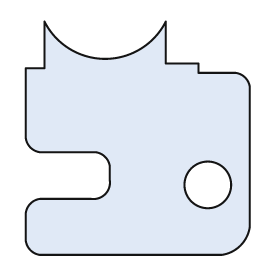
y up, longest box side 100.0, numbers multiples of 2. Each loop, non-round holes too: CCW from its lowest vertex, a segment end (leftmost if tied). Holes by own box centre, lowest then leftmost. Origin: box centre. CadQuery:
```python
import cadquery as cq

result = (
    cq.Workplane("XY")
    .moveTo(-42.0, -50.0)
    .lineTo(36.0, -50.0)
    .threePointArc((44.0, -46.0), (48.0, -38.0))
    .lineTo(48.0, 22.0)
    .threePointArc((46.0, 26.0), (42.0, 28.0))
    .lineTo(26.0, 28.0)
    .lineTo(26.0, 32.0)
    .lineTo(12.0, 32.0)
    .lineTo(12.0, 50.0)
    .threePointArc((-14.0, 34.0), (-40.0, 50.0))
    .lineTo(-40.0, 30.0)
    .lineTo(-48.0, 30.0)
    .lineTo(-48.0, 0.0)
    .threePointArc((-46.0, -4.0), (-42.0, -6.0))
    .lineTo(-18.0, -6.0)
    .threePointArc((-14.0, -8.0), (-12.0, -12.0))
    .lineTo(-12.0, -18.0)
    .threePointArc((-14.0, -24.0), (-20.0, -26.0))
    .lineTo(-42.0, -26.0)
    .threePointArc((-46.0, -28.0), (-48.0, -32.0))
    .lineTo(-48.0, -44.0)
    .threePointArc((-46.0, -48.0), (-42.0, -50.0))
    .close()
    .moveTo(30.0, -20.0)
    .circle(10.0)
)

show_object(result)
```